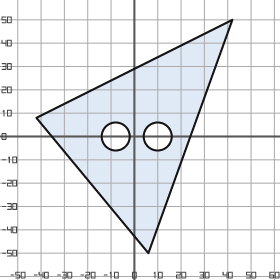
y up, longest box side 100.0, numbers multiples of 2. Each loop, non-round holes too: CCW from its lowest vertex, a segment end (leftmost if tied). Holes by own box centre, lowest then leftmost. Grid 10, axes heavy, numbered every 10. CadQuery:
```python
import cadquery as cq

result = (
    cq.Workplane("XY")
    .moveTo(6.0, -50.0)
    .lineTo(42.0, 50.0)
    .lineTo(-42.0, 8.0)
    .close()
    .moveTo(-8.0, 0.0)
    .circle(6.0)
    .moveTo(10.0, 0.0)
    .circle(6.0)
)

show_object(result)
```